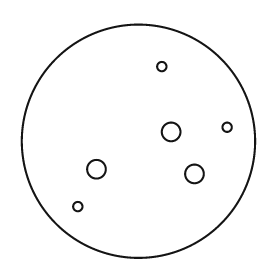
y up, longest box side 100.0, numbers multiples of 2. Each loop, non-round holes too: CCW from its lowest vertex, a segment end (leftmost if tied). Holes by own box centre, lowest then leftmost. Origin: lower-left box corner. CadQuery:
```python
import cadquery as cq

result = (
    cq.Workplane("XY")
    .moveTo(50.0, 50.0)
    .circle(50.0)
    .moveTo(24.0, 22.0)
    .circle(2.0)
    .moveTo(74.0, 36.0)
    .circle(4.0)
    .moveTo(32.0, 38.0)
    .circle(4.0)
    .moveTo(64.0, 54.0)
    .circle(4.0)
    .moveTo(88.0, 56.0)
    .circle(2.0)
    .moveTo(60.0, 82.0)
    .circle(2.0)
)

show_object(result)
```